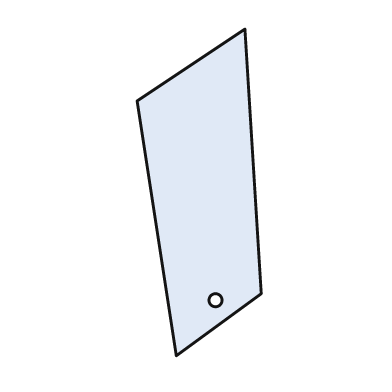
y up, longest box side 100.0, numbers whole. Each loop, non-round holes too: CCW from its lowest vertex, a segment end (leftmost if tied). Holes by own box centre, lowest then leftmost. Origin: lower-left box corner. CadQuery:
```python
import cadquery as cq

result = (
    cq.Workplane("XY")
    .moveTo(12.0, 0.0)
    .lineTo(38.0, 19.0)
    .lineTo(33.0, 100.0)
    .lineTo(0.0, 78.0)
    .close()
    .moveTo(24.0, 17.0)
    .circle(2.0)
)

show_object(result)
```